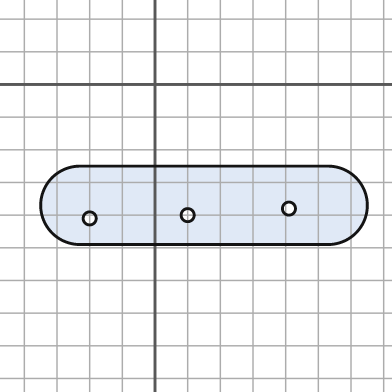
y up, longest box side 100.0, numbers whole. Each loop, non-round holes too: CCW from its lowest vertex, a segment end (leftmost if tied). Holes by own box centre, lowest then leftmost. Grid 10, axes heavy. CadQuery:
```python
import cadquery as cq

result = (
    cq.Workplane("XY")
    .moveTo(-23.0, -49.0)
    .lineTo(53.0, -49.0)
    .threePointArc((65.0, -37.0), (53.0, -25.0))
    .lineTo(-23.0, -25.0)
    .threePointArc((-35.0, -37.0), (-23.0, -49.0))
    .close()
    .moveTo(-20.0, -41.0)
    .circle(2.0)
    .moveTo(10.0, -40.0)
    .circle(2.0)
    .moveTo(41.0, -38.0)
    .circle(2.0)
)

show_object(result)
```